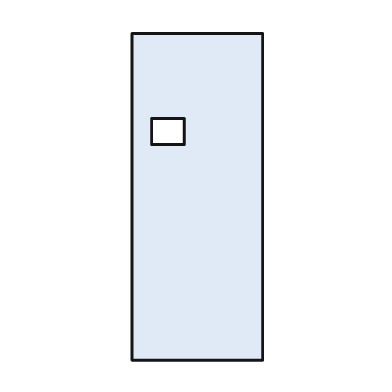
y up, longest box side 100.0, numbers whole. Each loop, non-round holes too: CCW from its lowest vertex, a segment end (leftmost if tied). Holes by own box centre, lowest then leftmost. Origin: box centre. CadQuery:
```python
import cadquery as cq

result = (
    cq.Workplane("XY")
    .moveTo(-20.0, -50.0)
    .lineTo(20.0, -50.0)
    .lineTo(20.0, 50.0)
    .lineTo(-20.0, 50.0)
    .close()
    .moveTo(-14.0, 16.0)
    .lineTo(-4.0, 16.0)
    .lineTo(-4.0, 24.0)
    .lineTo(-14.0, 24.0)
    .close()
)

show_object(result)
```